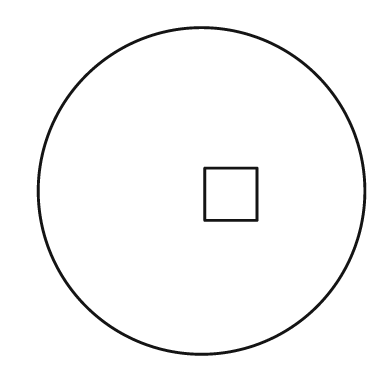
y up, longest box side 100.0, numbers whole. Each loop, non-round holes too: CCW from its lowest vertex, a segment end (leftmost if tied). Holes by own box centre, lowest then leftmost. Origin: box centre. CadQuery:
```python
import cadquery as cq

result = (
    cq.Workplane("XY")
    .moveTo(0.0, 0.0)
    .circle(50.0)
    .moveTo(1.0, -9.0)
    .lineTo(17.0, -9.0)
    .lineTo(17.0, 7.0)
    .lineTo(1.0, 7.0)
    .close()
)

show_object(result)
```